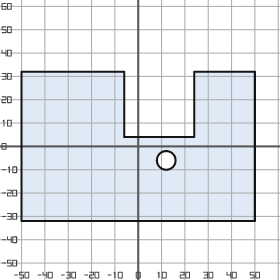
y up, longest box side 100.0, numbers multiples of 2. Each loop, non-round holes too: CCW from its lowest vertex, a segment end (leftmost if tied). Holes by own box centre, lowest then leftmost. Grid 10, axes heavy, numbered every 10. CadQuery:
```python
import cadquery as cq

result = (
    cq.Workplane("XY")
    .moveTo(-50.0, -32.0)
    .lineTo(50.0, -32.0)
    .lineTo(50.0, 32.0)
    .lineTo(24.0, 32.0)
    .lineTo(24.0, 4.0)
    .lineTo(-6.0, 4.0)
    .lineTo(-6.0, 32.0)
    .lineTo(-50.0, 32.0)
    .close()
    .moveTo(12.0, -6.0)
    .circle(4.0)
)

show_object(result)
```